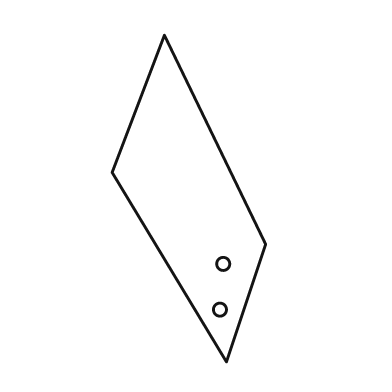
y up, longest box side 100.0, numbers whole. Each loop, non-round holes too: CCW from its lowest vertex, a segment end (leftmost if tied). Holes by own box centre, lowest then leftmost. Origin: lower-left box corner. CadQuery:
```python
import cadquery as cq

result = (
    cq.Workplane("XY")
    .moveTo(35.0, 0.0)
    .lineTo(47.0, 36.0)
    .lineTo(16.0, 100.0)
    .lineTo(0.0, 58.0)
    .close()
    .moveTo(33.0, 16.0)
    .circle(2.0)
    .moveTo(34.0, 30.0)
    .circle(2.0)
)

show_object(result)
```